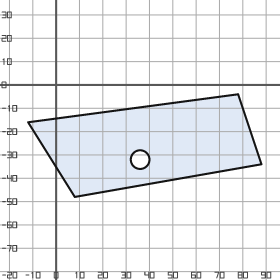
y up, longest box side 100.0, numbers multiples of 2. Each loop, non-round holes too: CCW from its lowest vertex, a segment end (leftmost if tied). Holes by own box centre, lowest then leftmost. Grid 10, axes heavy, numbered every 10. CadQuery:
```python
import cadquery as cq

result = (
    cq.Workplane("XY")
    .moveTo(8.0, -48.0)
    .lineTo(88.0, -34.0)
    .lineTo(78.0, -4.0)
    .lineTo(-12.0, -16.0)
    .close()
    .moveTo(36.0, -32.0)
    .circle(4.0)
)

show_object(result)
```